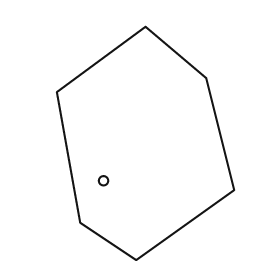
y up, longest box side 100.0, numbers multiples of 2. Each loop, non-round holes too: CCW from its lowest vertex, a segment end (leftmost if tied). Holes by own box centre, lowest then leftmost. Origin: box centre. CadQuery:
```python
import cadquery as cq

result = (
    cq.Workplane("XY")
    .moveTo(-4.0, -50.0)
    .lineTo(38.0, -20.0)
    .lineTo(26.0, 28.0)
    .lineTo(0.0, 50.0)
    .lineTo(-38.0, 22.0)
    .lineTo(-28.0, -34.0)
    .close()
    .moveTo(-18.0, -16.0)
    .circle(2.0)
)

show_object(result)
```